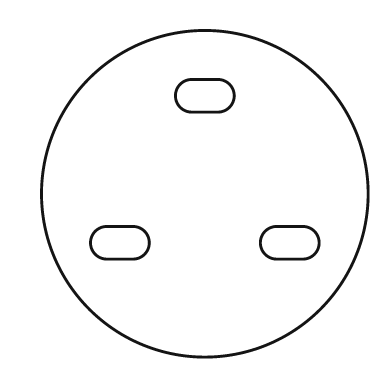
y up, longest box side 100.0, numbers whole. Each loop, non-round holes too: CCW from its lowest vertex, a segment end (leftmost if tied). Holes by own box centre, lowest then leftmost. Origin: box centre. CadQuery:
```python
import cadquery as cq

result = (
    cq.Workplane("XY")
    .moveTo(0.0, 0.0)
    .circle(50.0)
    .moveTo(-30.0, -20.0)
    .lineTo(-22.0, -20.0)
    .threePointArc((-17.0, -15.0), (-22.0, -10.0))
    .lineTo(-30.0, -10.0)
    .threePointArc((-35.0, -15.0), (-30.0, -20.0))
    .close()
    .moveTo(22.0, -20.0)
    .lineTo(30.0, -20.0)
    .threePointArc((35.0, -15.0), (30.0, -10.0))
    .lineTo(22.0, -10.0)
    .threePointArc((17.0, -15.0), (22.0, -20.0))
    .close()
    .moveTo(-4.0, 25.0)
    .lineTo(4.0, 25.0)
    .threePointArc((9.0, 30.0), (4.0, 35.0))
    .lineTo(-4.0, 35.0)
    .threePointArc((-9.0, 30.0), (-4.0, 25.0))
    .close()
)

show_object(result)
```